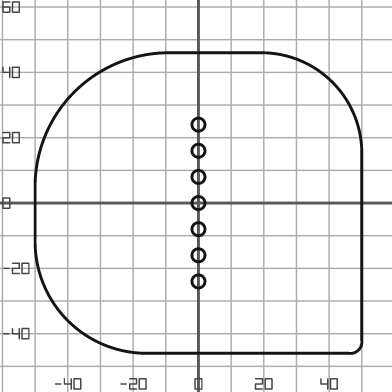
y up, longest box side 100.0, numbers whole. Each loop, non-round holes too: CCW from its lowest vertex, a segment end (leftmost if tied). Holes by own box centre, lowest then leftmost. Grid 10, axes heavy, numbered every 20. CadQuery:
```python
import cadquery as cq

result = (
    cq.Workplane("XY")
    .moveTo(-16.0, -46.0)
    .lineTo(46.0, -46.0)
    .threePointArc((49.0, -45.0), (50.0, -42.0))
    .lineTo(50.0, 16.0)
    .threePointArc((41.0, 37.0), (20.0, 46.0))
    .lineTo(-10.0, 46.0)
    .threePointArc((-38.0, 34.0), (-50.0, 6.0))
    .lineTo(-50.0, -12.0)
    .threePointArc((-40.0, -36.0), (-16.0, -46.0))
    .close()
    .moveTo(0.0, -24.0)
    .circle(2.0)
    .moveTo(0.0, -16.0)
    .circle(2.0)
    .moveTo(0.0, -8.0)
    .circle(2.0)
    .moveTo(0.0, 0.0)
    .circle(2.0)
    .moveTo(0.0, 8.0)
    .circle(2.0)
    .moveTo(0.0, 16.0)
    .circle(2.0)
    .moveTo(0.0, 24.0)
    .circle(2.0)
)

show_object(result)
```